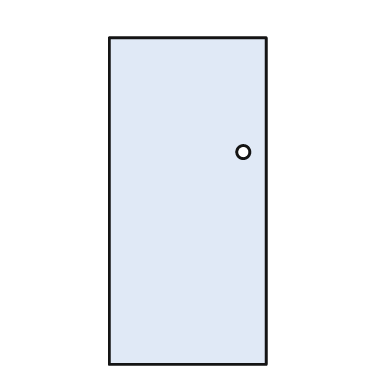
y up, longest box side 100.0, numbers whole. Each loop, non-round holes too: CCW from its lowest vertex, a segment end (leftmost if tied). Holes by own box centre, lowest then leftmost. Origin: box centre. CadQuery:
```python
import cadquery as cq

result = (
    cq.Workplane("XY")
    .moveTo(-24.0, -50.0)
    .lineTo(24.0, -50.0)
    .lineTo(24.0, 50.0)
    .lineTo(-24.0, 50.0)
    .close()
    .moveTo(17.0, 15.0)
    .circle(2.0)
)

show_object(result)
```